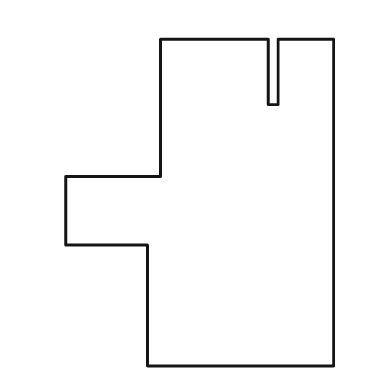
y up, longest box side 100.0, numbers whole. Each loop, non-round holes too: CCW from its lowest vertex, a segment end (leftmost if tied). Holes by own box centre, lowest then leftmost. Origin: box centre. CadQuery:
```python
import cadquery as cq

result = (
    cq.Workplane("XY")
    .moveTo(-16.0, -50.0)
    .lineTo(41.0, -50.0)
    .lineTo(41.0, 50.0)
    .lineTo(24.0, 50.0)
    .lineTo(24.0, 30.0)
    .lineTo(21.0, 30.0)
    .lineTo(21.0, 50.0)
    .lineTo(-12.0, 50.0)
    .lineTo(-12.0, 8.0)
    .lineTo(-41.0, 8.0)
    .lineTo(-41.0, -13.0)
    .lineTo(-16.0, -13.0)
    .close()
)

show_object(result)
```